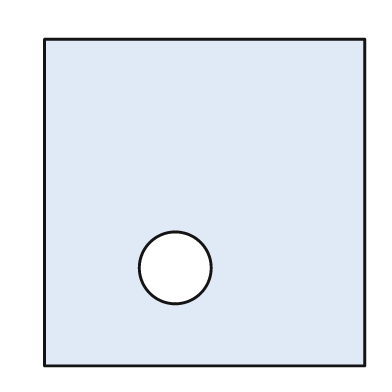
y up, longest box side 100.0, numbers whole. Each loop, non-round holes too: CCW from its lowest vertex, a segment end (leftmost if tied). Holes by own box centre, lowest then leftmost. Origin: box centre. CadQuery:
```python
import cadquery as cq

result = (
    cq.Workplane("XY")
    .moveTo(-49.0, -50.0)
    .lineTo(49.0, -50.0)
    .lineTo(49.0, 50.0)
    .lineTo(-49.0, 50.0)
    .close()
    .moveTo(-9.0, -20.0)
    .circle(11.0)
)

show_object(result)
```